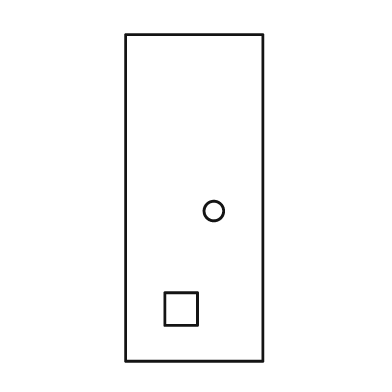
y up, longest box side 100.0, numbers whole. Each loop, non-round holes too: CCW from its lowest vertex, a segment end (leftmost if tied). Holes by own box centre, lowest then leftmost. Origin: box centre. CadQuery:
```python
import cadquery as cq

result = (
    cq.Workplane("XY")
    .moveTo(-21.0, -50.0)
    .lineTo(21.0, -50.0)
    .lineTo(21.0, 50.0)
    .lineTo(-21.0, 50.0)
    .close()
    .moveTo(-9.0, -39.0)
    .lineTo(1.0, -39.0)
    .lineTo(1.0, -29.0)
    .lineTo(-9.0, -29.0)
    .close()
    .moveTo(6.0, -4.0)
    .circle(3.0)
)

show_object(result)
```